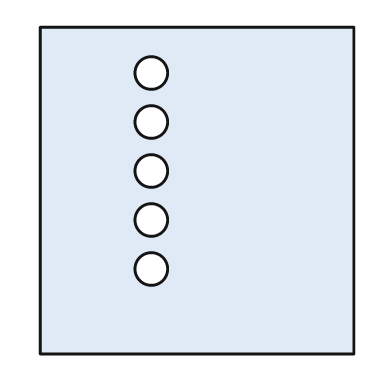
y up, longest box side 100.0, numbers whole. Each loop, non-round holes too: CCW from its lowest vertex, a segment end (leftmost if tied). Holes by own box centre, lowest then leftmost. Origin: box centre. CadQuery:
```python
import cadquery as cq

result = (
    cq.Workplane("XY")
    .moveTo(-48.0, -50.0)
    .lineTo(48.0, -50.0)
    .lineTo(48.0, 50.0)
    .lineTo(-48.0, 50.0)
    .close()
    .moveTo(-14.0, -24.0)
    .circle(5.0)
    .moveTo(-14.0, -9.0)
    .circle(5.0)
    .moveTo(-14.0, 6.0)
    .circle(5.0)
    .moveTo(-14.0, 21.0)
    .circle(5.0)
    .moveTo(-14.0, 36.0)
    .circle(5.0)
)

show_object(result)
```